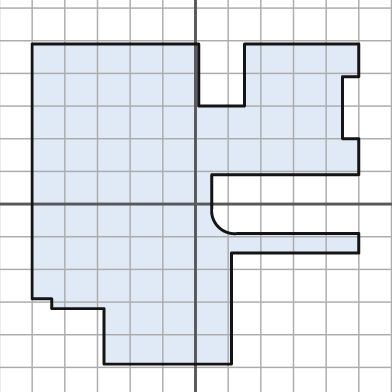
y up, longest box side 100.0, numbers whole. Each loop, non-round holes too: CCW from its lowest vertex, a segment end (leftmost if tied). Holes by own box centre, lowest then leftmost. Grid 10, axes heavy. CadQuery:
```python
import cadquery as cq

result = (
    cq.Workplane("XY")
    .moveTo(-28.0, -49.0)
    .lineTo(11.0, -49.0)
    .lineTo(11.0, -15.0)
    .lineTo(50.0, -15.0)
    .lineTo(50.0, -9.0)
    .lineTo(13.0, -9.0)
    .threePointArc((7.0, -7.0), (5.0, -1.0))
    .lineTo(5.0, 9.0)
    .lineTo(50.0, 9.0)
    .lineTo(50.0, 20.0)
    .lineTo(45.0, 20.0)
    .lineTo(45.0, 39.0)
    .lineTo(50.0, 39.0)
    .lineTo(50.0, 49.0)
    .lineTo(15.0, 49.0)
    .lineTo(15.0, 30.0)
    .lineTo(1.0, 30.0)
    .lineTo(1.0, 49.0)
    .lineTo(-50.0, 49.0)
    .lineTo(-50.0, -29.0)
    .lineTo(-44.0, -29.0)
    .lineTo(-44.0, -32.0)
    .lineTo(-28.0, -32.0)
    .close()
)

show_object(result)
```